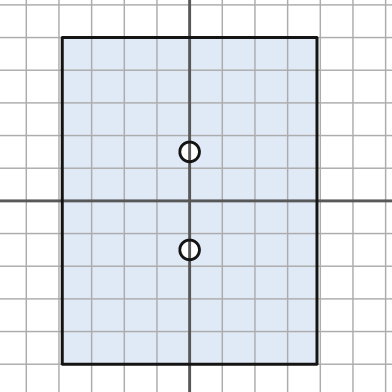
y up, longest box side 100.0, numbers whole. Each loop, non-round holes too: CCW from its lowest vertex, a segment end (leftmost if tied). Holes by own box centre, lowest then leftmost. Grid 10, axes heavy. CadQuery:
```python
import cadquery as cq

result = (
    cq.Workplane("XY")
    .moveTo(-39.0, -50.0)
    .lineTo(39.0, -50.0)
    .lineTo(39.0, 50.0)
    .lineTo(-39.0, 50.0)
    .close()
    .moveTo(0.0, -15.0)
    .circle(3.0)
    .moveTo(0.0, 15.0)
    .circle(3.0)
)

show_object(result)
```